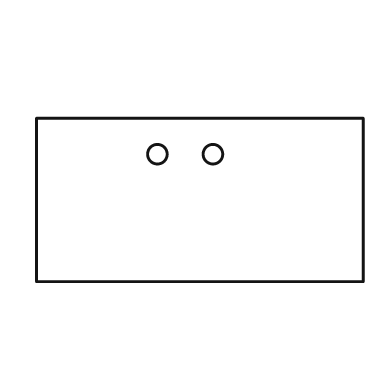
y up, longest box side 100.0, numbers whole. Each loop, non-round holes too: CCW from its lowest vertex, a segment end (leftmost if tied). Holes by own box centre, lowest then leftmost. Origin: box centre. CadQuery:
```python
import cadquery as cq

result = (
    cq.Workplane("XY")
    .moveTo(-50.0, -25.0)
    .lineTo(50.0, -25.0)
    .lineTo(50.0, 25.0)
    .lineTo(-50.0, 25.0)
    .close()
    .moveTo(-13.0, 14.0)
    .circle(3.0)
    .moveTo(4.0, 14.0)
    .circle(3.0)
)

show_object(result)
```